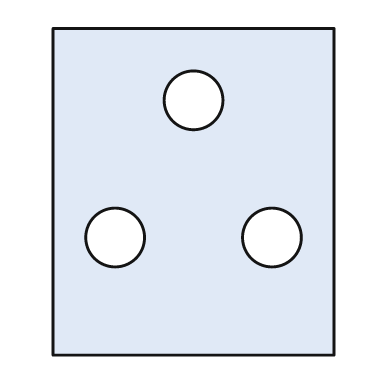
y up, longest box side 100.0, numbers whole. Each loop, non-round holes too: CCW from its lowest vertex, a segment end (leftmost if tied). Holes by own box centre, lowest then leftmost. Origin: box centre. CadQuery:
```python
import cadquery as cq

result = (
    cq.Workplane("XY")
    .moveTo(-43.0, -50.0)
    .lineTo(43.0, -50.0)
    .lineTo(43.0, 50.0)
    .lineTo(-43.0, 50.0)
    .close()
    .moveTo(-24.0, -14.0)
    .circle(9.0)
    .moveTo(24.0, -14.0)
    .circle(9.0)
    .moveTo(0.0, 28.0)
    .circle(9.0)
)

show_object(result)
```